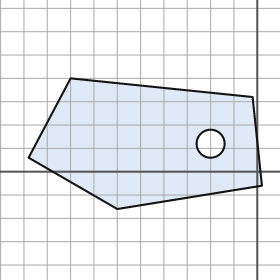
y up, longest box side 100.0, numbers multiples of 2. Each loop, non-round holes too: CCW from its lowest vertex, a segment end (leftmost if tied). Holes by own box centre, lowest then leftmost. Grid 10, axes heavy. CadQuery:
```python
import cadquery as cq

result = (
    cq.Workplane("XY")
    .moveTo(-60.0, -16.0)
    .lineTo(2.0, -6.0)
    .lineTo(-2.0, 32.0)
    .lineTo(-80.0, 40.0)
    .lineTo(-98.0, 6.0)
    .close()
    .moveTo(-20.0, 12.0)
    .circle(6.0)
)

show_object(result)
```